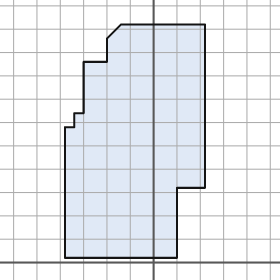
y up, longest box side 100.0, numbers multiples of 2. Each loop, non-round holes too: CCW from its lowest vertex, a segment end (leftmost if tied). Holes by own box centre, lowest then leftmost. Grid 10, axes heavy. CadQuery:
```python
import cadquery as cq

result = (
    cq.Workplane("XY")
    .moveTo(-38.0, 2.0)
    .lineTo(10.0, 2.0)
    .lineTo(10.0, 32.0)
    .lineTo(22.0, 32.0)
    .lineTo(22.0, 102.0)
    .lineTo(-14.0, 102.0)
    .lineTo(-20.0, 96.0)
    .lineTo(-20.0, 86.0)
    .lineTo(-30.0, 86.0)
    .lineTo(-30.0, 64.0)
    .lineTo(-34.0, 64.0)
    .lineTo(-34.0, 58.0)
    .lineTo(-38.0, 58.0)
    .close()
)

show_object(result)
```